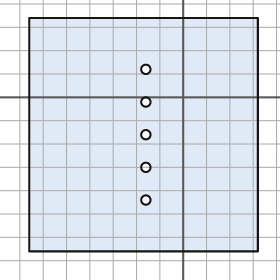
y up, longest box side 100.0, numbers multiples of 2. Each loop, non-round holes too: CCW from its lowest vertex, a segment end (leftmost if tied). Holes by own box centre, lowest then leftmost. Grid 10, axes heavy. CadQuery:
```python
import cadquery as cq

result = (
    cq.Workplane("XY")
    .moveTo(-66.0, -66.0)
    .lineTo(32.0, -66.0)
    .lineTo(32.0, 34.0)
    .lineTo(-66.0, 34.0)
    .close()
    .moveTo(-16.0, -44.0)
    .circle(2.0)
    .moveTo(-16.0, -30.0)
    .circle(2.0)
    .moveTo(-16.0, -16.0)
    .circle(2.0)
    .moveTo(-16.0, -2.0)
    .circle(2.0)
    .moveTo(-16.0, 12.0)
    .circle(2.0)
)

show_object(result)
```